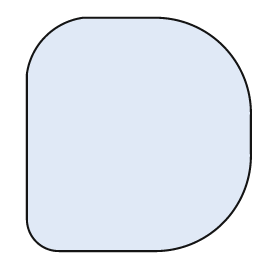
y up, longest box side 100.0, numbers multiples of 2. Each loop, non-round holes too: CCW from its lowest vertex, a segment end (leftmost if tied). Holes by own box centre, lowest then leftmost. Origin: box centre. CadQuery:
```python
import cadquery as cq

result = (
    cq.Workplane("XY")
    .moveTo(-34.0, -50.0)
    .lineTo(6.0, -50.0)
    .threePointArc((36.0, -38.0), (48.0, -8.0))
    .lineTo(48.0, 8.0)
    .threePointArc((36.0, 38.0), (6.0, 50.0))
    .lineTo(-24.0, 50.0)
    .threePointArc((-40.0, 42.0), (-48.0, 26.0))
    .lineTo(-48.0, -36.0)
    .threePointArc((-44.0, -46.0), (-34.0, -50.0))
    .close()
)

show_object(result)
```